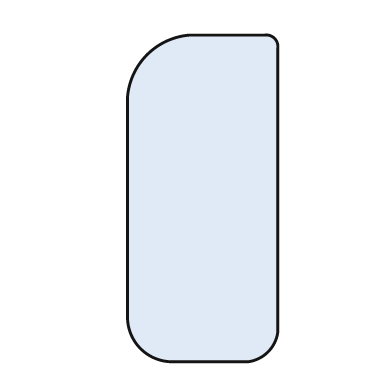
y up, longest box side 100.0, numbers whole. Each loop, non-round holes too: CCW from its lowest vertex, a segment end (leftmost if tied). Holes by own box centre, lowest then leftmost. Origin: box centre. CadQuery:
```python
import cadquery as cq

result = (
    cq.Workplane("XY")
    .moveTo(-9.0, -50.0)
    .lineTo(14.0, -50.0)
    .threePointArc((20.0, -47.0), (23.0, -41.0))
    .lineTo(23.0, 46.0)
    .threePointArc((22.0, 49.0), (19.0, 50.0))
    .lineTo(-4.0, 50.0)
    .threePointArc((-17.0, 44.0), (-23.0, 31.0))
    .lineTo(-23.0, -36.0)
    .threePointArc((-19.0, -46.0), (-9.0, -50.0))
    .close()
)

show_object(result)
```